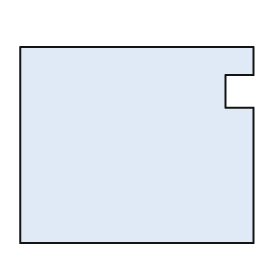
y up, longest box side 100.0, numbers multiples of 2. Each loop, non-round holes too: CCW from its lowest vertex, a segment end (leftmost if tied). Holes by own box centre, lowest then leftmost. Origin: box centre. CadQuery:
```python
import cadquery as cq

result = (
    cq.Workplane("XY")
    .moveTo(-50.0, -42.0)
    .lineTo(50.0, -42.0)
    .lineTo(50.0, 16.0)
    .lineTo(38.0, 16.0)
    .lineTo(38.0, 30.0)
    .lineTo(50.0, 30.0)
    .lineTo(50.0, 42.0)
    .lineTo(-50.0, 42.0)
    .close()
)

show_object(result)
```